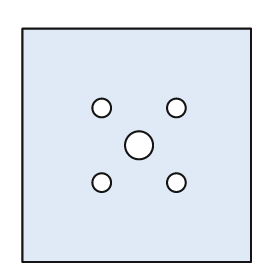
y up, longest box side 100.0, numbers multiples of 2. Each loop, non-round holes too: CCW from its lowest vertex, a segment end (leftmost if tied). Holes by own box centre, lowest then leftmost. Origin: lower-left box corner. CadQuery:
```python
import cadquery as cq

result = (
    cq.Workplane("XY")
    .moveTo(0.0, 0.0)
    .lineTo(98.0, 0.0)
    .lineTo(98.0, 100.0)
    .lineTo(0.0, 100.0)
    .close()
    .moveTo(34.0, 34.0)
    .circle(4.0)
    .moveTo(66.0, 34.0)
    .circle(4.0)
    .moveTo(50.0, 50.0)
    .circle(6.0)
    .moveTo(34.0, 66.0)
    .circle(4.0)
    .moveTo(66.0, 66.0)
    .circle(4.0)
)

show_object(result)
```